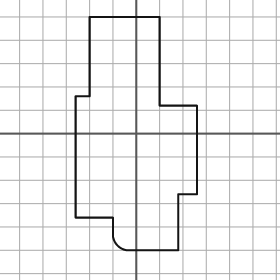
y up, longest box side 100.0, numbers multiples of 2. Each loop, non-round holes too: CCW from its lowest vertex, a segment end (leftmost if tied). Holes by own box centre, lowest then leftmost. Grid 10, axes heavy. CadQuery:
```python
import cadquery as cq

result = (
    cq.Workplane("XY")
    .moveTo(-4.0, -50.0)
    .lineTo(18.0, -50.0)
    .lineTo(18.0, -26.0)
    .lineTo(26.0, -26.0)
    .lineTo(26.0, 12.0)
    .lineTo(10.0, 12.0)
    .lineTo(10.0, 50.0)
    .lineTo(-20.0, 50.0)
    .lineTo(-20.0, 16.0)
    .lineTo(-26.0, 16.0)
    .lineTo(-26.0, -36.0)
    .lineTo(-10.0, -36.0)
    .lineTo(-10.0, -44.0)
    .threePointArc((-8.0, -48.0), (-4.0, -50.0))
    .close()
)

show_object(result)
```